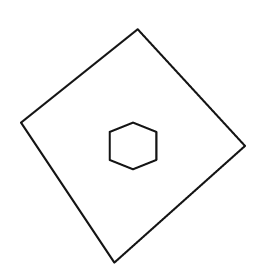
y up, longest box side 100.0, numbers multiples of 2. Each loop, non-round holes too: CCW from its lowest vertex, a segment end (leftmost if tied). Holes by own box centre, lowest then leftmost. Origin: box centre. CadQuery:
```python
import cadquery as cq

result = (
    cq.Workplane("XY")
    .moveTo(-8.0, -50.0)
    .lineTo(48.0, 0.0)
    .lineTo(2.0, 50.0)
    .lineTo(-48.0, 10.0)
    .close()
    .moveTo(0.0, -10.0)
    .lineTo(10.0, -6.0)
    .lineTo(10.0, 6.0)
    .lineTo(0.0, 10.0)
    .lineTo(-10.0, 6.0)
    .lineTo(-10.0, -6.0)
    .close()
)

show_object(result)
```